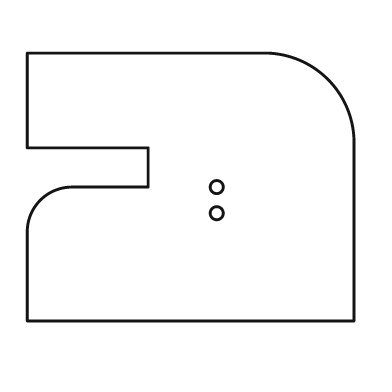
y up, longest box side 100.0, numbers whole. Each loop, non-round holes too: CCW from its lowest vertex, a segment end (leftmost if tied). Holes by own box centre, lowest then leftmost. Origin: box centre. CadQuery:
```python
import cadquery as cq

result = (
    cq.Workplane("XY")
    .moveTo(-50.0, -41.0)
    .lineTo(50.0, -41.0)
    .lineTo(50.0, 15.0)
    .threePointArc((42.0, 33.0), (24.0, 41.0))
    .lineTo(-50.0, 41.0)
    .lineTo(-50.0, 12.0)
    .lineTo(-13.0, 12.0)
    .lineTo(-13.0, 0.0)
    .lineTo(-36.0, 0.0)
    .threePointArc((-46.0, -4.0), (-50.0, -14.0))
    .close()
    .moveTo(8.0, -8.0)
    .circle(2.0)
    .moveTo(8.0, 0.0)
    .circle(2.0)
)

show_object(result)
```